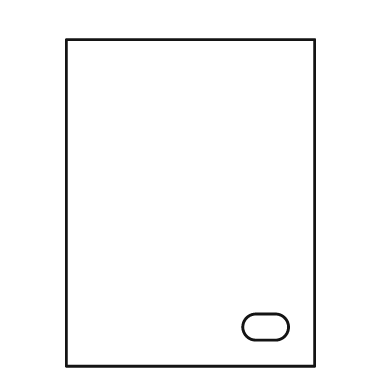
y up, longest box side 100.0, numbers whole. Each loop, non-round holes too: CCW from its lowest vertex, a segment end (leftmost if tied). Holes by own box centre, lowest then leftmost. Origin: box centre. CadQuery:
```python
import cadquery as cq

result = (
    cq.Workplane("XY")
    .moveTo(-38.0, -50.0)
    .lineTo(38.0, -50.0)
    .lineTo(38.0, 50.0)
    .lineTo(-38.0, 50.0)
    .close()
    .moveTo(20.0, -42.0)
    .lineTo(26.0, -42.0)
    .threePointArc((30.0, -38.0), (26.0, -34.0))
    .lineTo(20.0, -34.0)
    .threePointArc((16.0, -38.0), (20.0, -42.0))
    .close()
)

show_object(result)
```